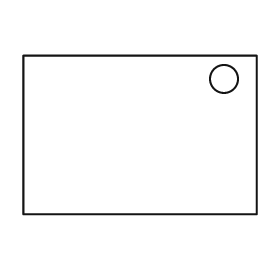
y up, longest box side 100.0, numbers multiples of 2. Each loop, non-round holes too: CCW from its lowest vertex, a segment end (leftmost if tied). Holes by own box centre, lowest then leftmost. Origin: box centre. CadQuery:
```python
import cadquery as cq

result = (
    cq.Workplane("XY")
    .moveTo(-50.0, -34.0)
    .lineTo(50.0, -34.0)
    .lineTo(50.0, 34.0)
    .lineTo(-50.0, 34.0)
    .close()
    .moveTo(36.0, 24.0)
    .circle(6.0)
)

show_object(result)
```